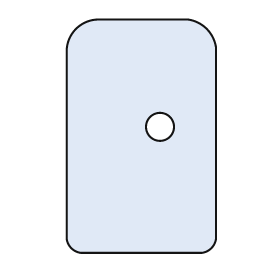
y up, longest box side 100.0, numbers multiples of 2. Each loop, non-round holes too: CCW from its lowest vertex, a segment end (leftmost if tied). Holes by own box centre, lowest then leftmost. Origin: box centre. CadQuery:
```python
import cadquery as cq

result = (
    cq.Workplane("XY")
    .moveTo(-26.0, -50.0)
    .lineTo(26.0, -50.0)
    .threePointArc((30.0, -48.0), (32.0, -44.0))
    .lineTo(32.0, 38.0)
    .threePointArc((28.0, 46.0), (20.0, 50.0))
    .lineTo(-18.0, 50.0)
    .threePointArc((-28.0, 46.0), (-32.0, 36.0))
    .lineTo(-32.0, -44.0)
    .threePointArc((-30.0, -48.0), (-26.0, -50.0))
    .close()
    .moveTo(8.0, 4.0)
    .circle(6.0)
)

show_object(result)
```